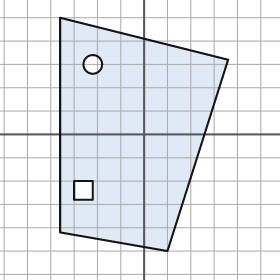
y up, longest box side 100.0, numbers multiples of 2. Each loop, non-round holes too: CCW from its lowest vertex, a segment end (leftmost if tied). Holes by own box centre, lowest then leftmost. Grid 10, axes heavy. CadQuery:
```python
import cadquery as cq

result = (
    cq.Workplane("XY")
    .moveTo(10.0, -50.0)
    .lineTo(36.0, 32.0)
    .lineTo(-36.0, 50.0)
    .lineTo(-36.0, -42.0)
    .close()
    .moveTo(-30.0, -28.0)
    .lineTo(-22.0, -28.0)
    .lineTo(-22.0, -20.0)
    .lineTo(-30.0, -20.0)
    .close()
    .moveTo(-22.0, 30.0)
    .circle(4.0)
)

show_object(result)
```